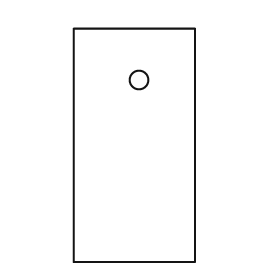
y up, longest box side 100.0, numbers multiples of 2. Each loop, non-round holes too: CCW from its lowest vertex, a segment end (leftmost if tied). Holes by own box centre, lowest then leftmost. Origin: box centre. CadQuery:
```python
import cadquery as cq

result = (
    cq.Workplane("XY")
    .moveTo(-26.0, -50.0)
    .lineTo(26.0, -50.0)
    .lineTo(26.0, 50.0)
    .lineTo(-26.0, 50.0)
    .close()
    .moveTo(2.0, 28.0)
    .circle(4.0)
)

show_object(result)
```